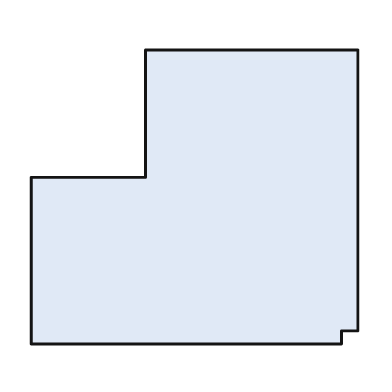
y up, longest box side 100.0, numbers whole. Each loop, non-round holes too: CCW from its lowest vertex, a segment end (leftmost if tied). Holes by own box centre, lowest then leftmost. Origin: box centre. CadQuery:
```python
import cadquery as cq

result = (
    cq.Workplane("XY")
    .moveTo(-50.0, -45.0)
    .lineTo(45.0, -45.0)
    .lineTo(45.0, -41.0)
    .lineTo(50.0, -41.0)
    .lineTo(50.0, 45.0)
    .lineTo(-15.0, 45.0)
    .lineTo(-15.0, 6.0)
    .lineTo(-50.0, 6.0)
    .close()
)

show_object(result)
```